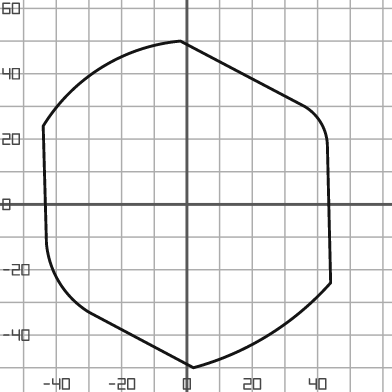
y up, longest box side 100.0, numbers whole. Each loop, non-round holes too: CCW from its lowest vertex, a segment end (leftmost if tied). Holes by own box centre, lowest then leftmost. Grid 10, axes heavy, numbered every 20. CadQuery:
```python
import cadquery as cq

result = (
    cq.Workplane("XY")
    .moveTo(2.0, -50.0)
    .threePointArc((25.0, -40.0), (44.0, -24.0))
    .lineTo(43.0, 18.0)
    .threePointArc((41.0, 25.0), (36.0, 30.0))
    .lineTo(-2.0, 50.0)
    .threePointArc((-26.0, 42.0), (-44.0, 24.0))
    .lineTo(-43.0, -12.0)
    .threePointArc((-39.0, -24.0), (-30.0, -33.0))
    .close()
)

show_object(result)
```